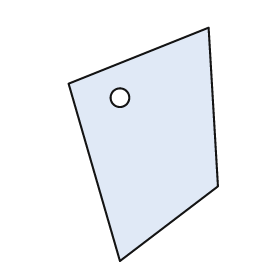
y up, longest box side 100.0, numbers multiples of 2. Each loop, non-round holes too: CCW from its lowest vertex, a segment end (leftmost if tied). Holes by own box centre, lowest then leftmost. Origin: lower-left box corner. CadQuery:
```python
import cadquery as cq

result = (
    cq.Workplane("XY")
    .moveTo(22.0, 0.0)
    .lineTo(64.0, 32.0)
    .lineTo(60.0, 100.0)
    .lineTo(0.0, 76.0)
    .close()
    .moveTo(22.0, 70.0)
    .circle(4.0)
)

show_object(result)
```